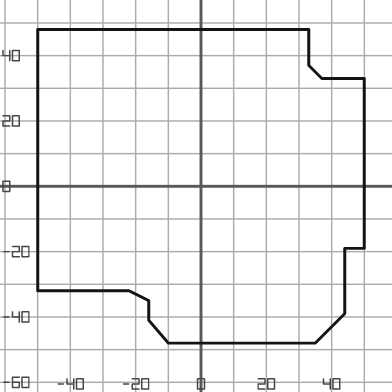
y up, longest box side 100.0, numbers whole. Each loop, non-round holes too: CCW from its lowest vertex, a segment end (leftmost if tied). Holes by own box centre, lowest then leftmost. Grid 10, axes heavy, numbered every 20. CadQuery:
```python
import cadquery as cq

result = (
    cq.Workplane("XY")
    .moveTo(-10.0, -48.0)
    .lineTo(35.0, -48.0)
    .lineTo(44.0, -39.0)
    .lineTo(44.0, -19.0)
    .lineTo(50.0, -19.0)
    .lineTo(50.0, 33.0)
    .lineTo(37.0, 33.0)
    .lineTo(33.0, 37.0)
    .lineTo(33.0, 48.0)
    .lineTo(-50.0, 48.0)
    .lineTo(-50.0, -32.0)
    .lineTo(-22.0, -32.0)
    .lineTo(-16.0, -35.0)
    .lineTo(-16.0, -41.0)
    .close()
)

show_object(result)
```